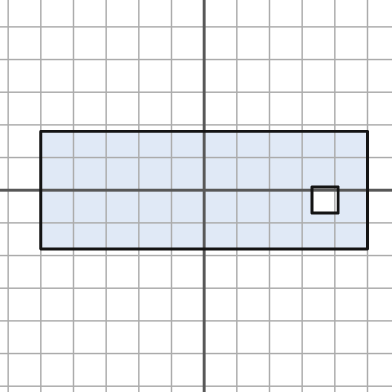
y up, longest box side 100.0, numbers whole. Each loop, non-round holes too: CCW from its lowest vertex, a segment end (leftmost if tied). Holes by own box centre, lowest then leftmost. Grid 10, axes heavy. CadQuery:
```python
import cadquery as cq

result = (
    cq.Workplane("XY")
    .moveTo(-50.0, -18.0)
    .lineTo(50.0, -18.0)
    .lineTo(50.0, 18.0)
    .lineTo(-50.0, 18.0)
    .close()
    .moveTo(33.0, -7.0)
    .lineTo(41.0, -7.0)
    .lineTo(41.0, 1.0)
    .lineTo(33.0, 1.0)
    .close()
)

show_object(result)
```